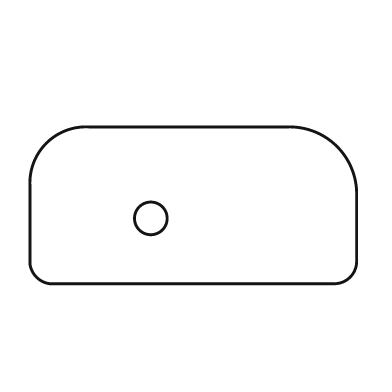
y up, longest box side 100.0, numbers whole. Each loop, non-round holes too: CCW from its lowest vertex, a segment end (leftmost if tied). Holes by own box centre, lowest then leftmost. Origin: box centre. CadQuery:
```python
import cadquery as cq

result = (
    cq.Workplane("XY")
    .moveTo(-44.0, -24.0)
    .lineTo(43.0, -24.0)
    .threePointArc((48.0, -22.0), (50.0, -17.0))
    .lineTo(50.0, 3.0)
    .threePointArc((44.0, 18.0), (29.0, 24.0))
    .lineTo(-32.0, 24.0)
    .threePointArc((-45.0, 19.0), (-50.0, 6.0))
    .lineTo(-50.0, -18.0)
    .threePointArc((-48.0, -22.0), (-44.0, -24.0))
    .close()
    .moveTo(-13.0, -4.0)
    .circle(5.0)
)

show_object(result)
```